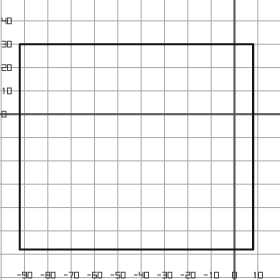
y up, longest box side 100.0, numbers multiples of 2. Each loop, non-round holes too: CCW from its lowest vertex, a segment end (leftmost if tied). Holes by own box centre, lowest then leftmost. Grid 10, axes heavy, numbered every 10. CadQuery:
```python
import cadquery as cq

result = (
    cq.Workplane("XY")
    .moveTo(-92.0, -58.0)
    .lineTo(8.0, -58.0)
    .lineTo(8.0, 30.0)
    .lineTo(-92.0, 30.0)
    .close()
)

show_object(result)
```